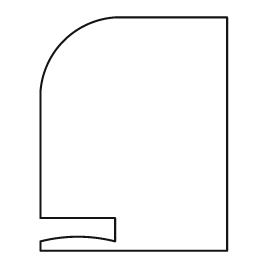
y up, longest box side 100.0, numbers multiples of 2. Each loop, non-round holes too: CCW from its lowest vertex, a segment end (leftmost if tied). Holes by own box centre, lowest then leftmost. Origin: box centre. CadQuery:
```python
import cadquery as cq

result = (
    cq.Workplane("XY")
    .moveTo(-40.0, -50.0)
    .lineTo(40.0, -50.0)
    .lineTo(40.0, 50.0)
    .lineTo(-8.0, 50.0)
    .threePointArc((-30.0, 40.0), (-40.0, 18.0))
    .lineTo(-40.0, -36.0)
    .lineTo(-8.0, -36.0)
    .lineTo(-8.0, -46.0)
    .threePointArc((-24.0, -44.0), (-40.0, -46.0))
    .close()
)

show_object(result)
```